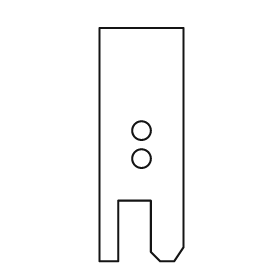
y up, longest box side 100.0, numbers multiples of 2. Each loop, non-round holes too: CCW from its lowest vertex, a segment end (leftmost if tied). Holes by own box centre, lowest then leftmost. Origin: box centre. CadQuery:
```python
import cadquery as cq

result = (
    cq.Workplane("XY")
    .moveTo(-18.0, -50.0)
    .lineTo(-10.0, -50.0)
    .lineTo(-10.0, -24.0)
    .lineTo(4.0, -24.0)
    .lineTo(4.0, -46.0)
    .lineTo(8.0, -50.0)
    .lineTo(14.0, -50.0)
    .lineTo(18.0, -44.0)
    .lineTo(18.0, 50.0)
    .lineTo(-18.0, 50.0)
    .close()
    .moveTo(0.0, -6.0)
    .circle(4.0)
    .moveTo(0.0, 6.0)
    .circle(4.0)
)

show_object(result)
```